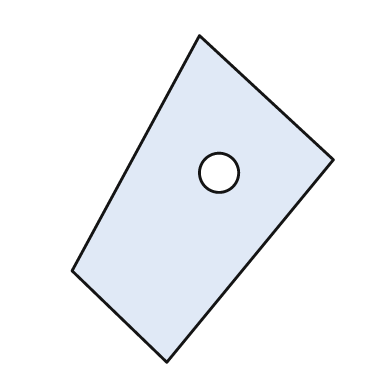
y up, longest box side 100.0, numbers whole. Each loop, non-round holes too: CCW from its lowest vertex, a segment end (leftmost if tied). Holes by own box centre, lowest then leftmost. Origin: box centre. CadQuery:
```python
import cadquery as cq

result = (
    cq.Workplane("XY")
    .moveTo(-11.0, -50.0)
    .lineTo(40.0, 12.0)
    .lineTo(-1.0, 50.0)
    .lineTo(-40.0, -22.0)
    .close()
    .moveTo(5.0, 8.0)
    .circle(6.0)
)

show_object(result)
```